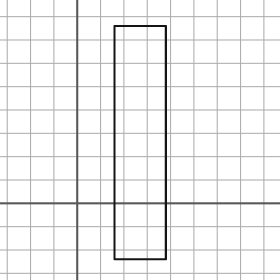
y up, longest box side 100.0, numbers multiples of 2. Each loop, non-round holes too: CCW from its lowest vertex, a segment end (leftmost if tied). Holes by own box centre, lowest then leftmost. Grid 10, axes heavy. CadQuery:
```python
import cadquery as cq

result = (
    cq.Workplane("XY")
    .moveTo(16.0, -24.0)
    .lineTo(38.0, -24.0)
    .lineTo(38.0, 76.0)
    .lineTo(16.0, 76.0)
    .close()
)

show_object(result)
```